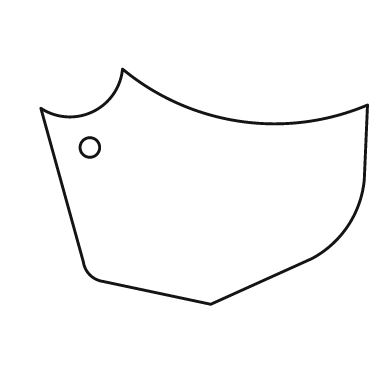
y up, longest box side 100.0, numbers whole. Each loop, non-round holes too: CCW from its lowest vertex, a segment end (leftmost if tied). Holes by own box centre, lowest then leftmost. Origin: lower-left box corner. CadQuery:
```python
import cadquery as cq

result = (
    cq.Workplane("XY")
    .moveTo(52.0, 0.0)
    .lineTo(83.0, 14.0)
    .threePointArc((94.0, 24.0), (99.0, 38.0))
    .lineTo(100.0, 61.0)
    .threePointArc((61.0, 56.0), (25.0, 72.0))
    .threePointArc((16.0, 59.0), (0.0, 60.0))
    .lineTo(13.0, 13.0)
    .threePointArc((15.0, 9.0), (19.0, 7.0))
    .close()
    .moveTo(15.0, 48.0)
    .circle(3.0)
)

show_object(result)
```